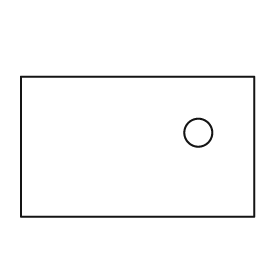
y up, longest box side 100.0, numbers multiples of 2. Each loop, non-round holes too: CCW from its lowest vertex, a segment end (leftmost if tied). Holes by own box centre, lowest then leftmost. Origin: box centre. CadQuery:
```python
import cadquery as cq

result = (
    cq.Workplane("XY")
    .moveTo(-50.0, -30.0)
    .lineTo(50.0, -30.0)
    .lineTo(50.0, 30.0)
    .lineTo(-50.0, 30.0)
    .close()
    .moveTo(26.0, 6.0)
    .circle(6.0)
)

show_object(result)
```